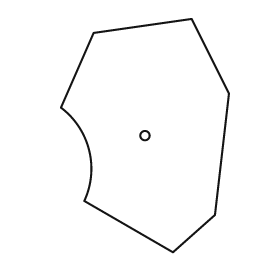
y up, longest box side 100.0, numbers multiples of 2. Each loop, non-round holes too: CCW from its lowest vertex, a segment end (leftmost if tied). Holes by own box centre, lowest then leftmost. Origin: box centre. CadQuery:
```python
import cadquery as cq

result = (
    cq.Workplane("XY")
    .moveTo(12.0, -50.0)
    .lineTo(30.0, -34.0)
    .lineTo(36.0, 18.0)
    .lineTo(20.0, 50.0)
    .lineTo(-22.0, 44.0)
    .lineTo(-36.0, 12.0)
    .threePointArc((-24.0, -6.0), (-26.0, -28.0))
    .close()
    .moveTo(0.0, 0.0)
    .circle(2.0)
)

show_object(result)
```